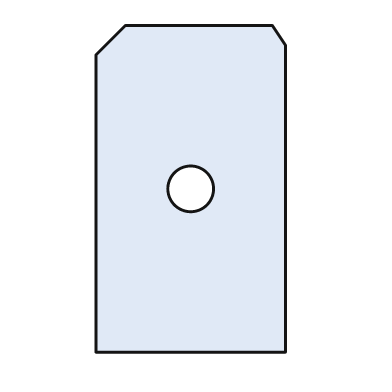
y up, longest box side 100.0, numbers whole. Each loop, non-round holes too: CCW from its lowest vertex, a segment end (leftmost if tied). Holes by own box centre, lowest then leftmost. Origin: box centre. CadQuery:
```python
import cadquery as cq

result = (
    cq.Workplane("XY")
    .moveTo(-29.0, -50.0)
    .lineTo(29.0, -50.0)
    .lineTo(29.0, 44.0)
    .lineTo(25.0, 50.0)
    .lineTo(-20.0, 50.0)
    .lineTo(-29.0, 41.0)
    .close()
    .moveTo(0.0, 0.0)
    .circle(7.0)
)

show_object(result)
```